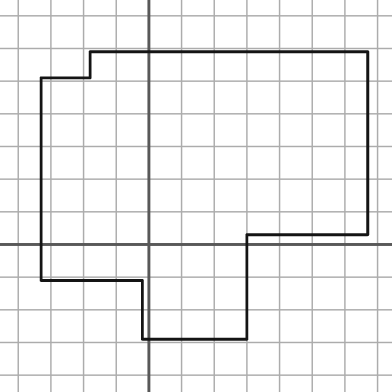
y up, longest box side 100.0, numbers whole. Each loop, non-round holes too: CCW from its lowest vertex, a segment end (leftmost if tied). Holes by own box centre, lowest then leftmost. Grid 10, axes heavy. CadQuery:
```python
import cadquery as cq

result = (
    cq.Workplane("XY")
    .moveTo(-2.0, -29.0)
    .lineTo(30.0, -29.0)
    .lineTo(30.0, 3.0)
    .lineTo(67.0, 3.0)
    .lineTo(67.0, 59.0)
    .lineTo(-18.0, 59.0)
    .lineTo(-18.0, 51.0)
    .lineTo(-33.0, 51.0)
    .lineTo(-33.0, -11.0)
    .lineTo(-2.0, -11.0)
    .close()
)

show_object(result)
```